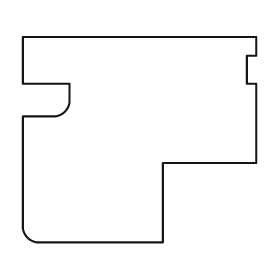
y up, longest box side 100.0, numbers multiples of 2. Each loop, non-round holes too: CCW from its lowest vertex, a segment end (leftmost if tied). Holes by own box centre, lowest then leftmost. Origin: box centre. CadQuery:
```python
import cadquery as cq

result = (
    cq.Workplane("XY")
    .moveTo(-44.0, -44.0)
    .lineTo(10.0, -44.0)
    .lineTo(10.0, -10.0)
    .lineTo(50.0, -10.0)
    .lineTo(50.0, 24.0)
    .lineTo(46.0, 24.0)
    .lineTo(46.0, 36.0)
    .lineTo(50.0, 36.0)
    .lineTo(50.0, 44.0)
    .lineTo(-50.0, 44.0)
    .lineTo(-50.0, 24.0)
    .lineTo(-30.0, 24.0)
    .lineTo(-30.0, 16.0)
    .threePointArc((-32.0, 12.0), (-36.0, 10.0))
    .lineTo(-50.0, 10.0)
    .lineTo(-50.0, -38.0)
    .threePointArc((-48.0, -42.0), (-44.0, -44.0))
    .close()
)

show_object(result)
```